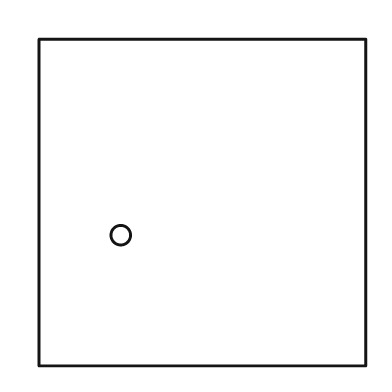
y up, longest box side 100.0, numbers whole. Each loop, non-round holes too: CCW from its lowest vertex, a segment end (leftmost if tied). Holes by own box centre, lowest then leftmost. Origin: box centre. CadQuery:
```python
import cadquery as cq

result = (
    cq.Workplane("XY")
    .moveTo(-50.0, -50.0)
    .lineTo(50.0, -50.0)
    .lineTo(50.0, 50.0)
    .lineTo(-50.0, 50.0)
    .close()
    .moveTo(-25.0, -10.0)
    .circle(3.0)
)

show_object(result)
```